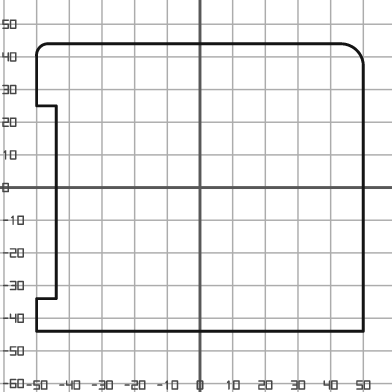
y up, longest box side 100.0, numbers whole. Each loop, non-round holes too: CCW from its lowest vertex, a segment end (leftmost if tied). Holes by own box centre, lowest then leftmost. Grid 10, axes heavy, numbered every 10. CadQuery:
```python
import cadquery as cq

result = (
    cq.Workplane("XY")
    .moveTo(-50.0, -44.0)
    .lineTo(50.0, -44.0)
    .lineTo(50.0, 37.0)
    .threePointArc((48.0, 42.0), (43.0, 44.0))
    .lineTo(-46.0, 44.0)
    .threePointArc((-49.0, 43.0), (-50.0, 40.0))
    .lineTo(-50.0, 25.0)
    .lineTo(-44.0, 25.0)
    .lineTo(-44.0, -34.0)
    .lineTo(-50.0, -34.0)
    .close()
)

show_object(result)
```